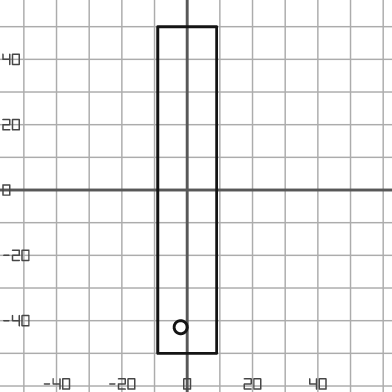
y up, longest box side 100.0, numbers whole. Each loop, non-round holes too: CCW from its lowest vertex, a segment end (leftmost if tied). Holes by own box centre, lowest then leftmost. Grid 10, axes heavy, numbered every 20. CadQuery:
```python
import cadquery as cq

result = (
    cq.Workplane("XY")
    .moveTo(-9.0, -50.0)
    .lineTo(9.0, -50.0)
    .lineTo(9.0, 50.0)
    .lineTo(-9.0, 50.0)
    .close()
    .moveTo(-2.0, -42.0)
    .circle(2.0)
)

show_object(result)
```